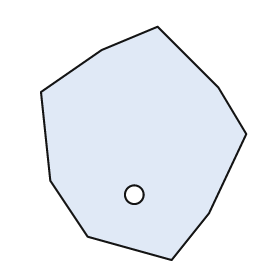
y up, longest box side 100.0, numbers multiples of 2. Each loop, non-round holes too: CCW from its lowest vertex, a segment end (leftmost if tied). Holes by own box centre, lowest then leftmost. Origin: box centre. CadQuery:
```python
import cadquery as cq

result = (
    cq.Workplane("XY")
    .moveTo(12.0, -50.0)
    .lineTo(28.0, -30.0)
    .lineTo(44.0, 4.0)
    .lineTo(32.0, 24.0)
    .lineTo(6.0, 50.0)
    .lineTo(-18.0, 40.0)
    .lineTo(-44.0, 22.0)
    .lineTo(-40.0, -16.0)
    .lineTo(-24.0, -40.0)
    .close()
    .moveTo(-4.0, -22.0)
    .circle(4.0)
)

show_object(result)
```